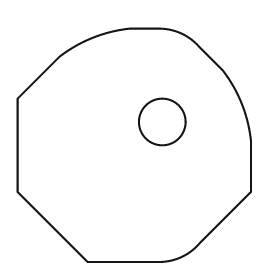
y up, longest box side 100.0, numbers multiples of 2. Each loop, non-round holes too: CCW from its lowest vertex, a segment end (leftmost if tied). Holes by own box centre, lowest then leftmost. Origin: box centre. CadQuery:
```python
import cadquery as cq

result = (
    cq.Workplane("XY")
    .moveTo(-20.0, -50.0)
    .lineTo(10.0, -50.0)
    .threePointArc((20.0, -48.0), (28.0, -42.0))
    .lineTo(50.0, -20.0)
    .lineTo(50.0, 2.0)
    .threePointArc((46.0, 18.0), (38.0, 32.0))
    .lineTo(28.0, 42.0)
    .threePointArc((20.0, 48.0), (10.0, 50.0))
    .lineTo(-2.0, 50.0)
    .threePointArc((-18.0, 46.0), (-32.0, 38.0))
    .lineTo(-50.0, 20.0)
    .lineTo(-50.0, -20.0)
    .close()
    .moveTo(12.0, 10.0)
    .circle(10.0)
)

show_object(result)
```